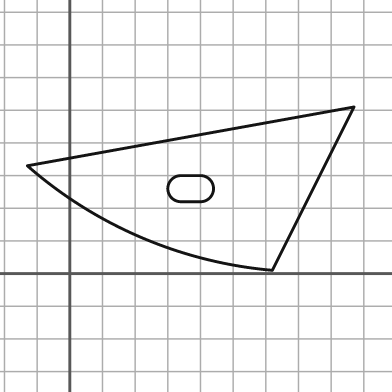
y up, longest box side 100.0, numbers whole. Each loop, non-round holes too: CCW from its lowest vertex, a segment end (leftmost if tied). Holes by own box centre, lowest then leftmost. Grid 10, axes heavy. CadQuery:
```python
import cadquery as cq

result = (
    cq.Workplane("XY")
    .moveTo(62.0, 1.0)
    .lineTo(87.0, 51.0)
    .lineTo(-13.0, 33.0)
    .threePointArc((22.0, 11.0), (62.0, 1.0))
    .close()
    .moveTo(34.0, 22.0)
    .lineTo(40.0, 22.0)
    .threePointArc((44.0, 26.0), (40.0, 30.0))
    .lineTo(34.0, 30.0)
    .threePointArc((30.0, 26.0), (34.0, 22.0))
    .close()
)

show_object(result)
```